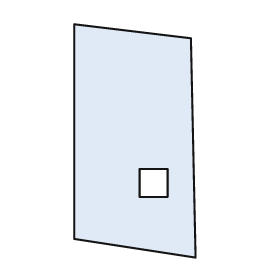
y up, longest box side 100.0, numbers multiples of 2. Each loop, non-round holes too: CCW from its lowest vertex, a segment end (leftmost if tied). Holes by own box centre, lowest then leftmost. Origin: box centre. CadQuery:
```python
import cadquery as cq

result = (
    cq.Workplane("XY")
    .moveTo(26.0, -50.0)
    .lineTo(24.0, 44.0)
    .lineTo(-26.0, 50.0)
    .lineTo(-26.0, -42.0)
    .close()
    .moveTo(2.0, -24.0)
    .lineTo(14.0, -24.0)
    .lineTo(14.0, -12.0)
    .lineTo(2.0, -12.0)
    .close()
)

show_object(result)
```